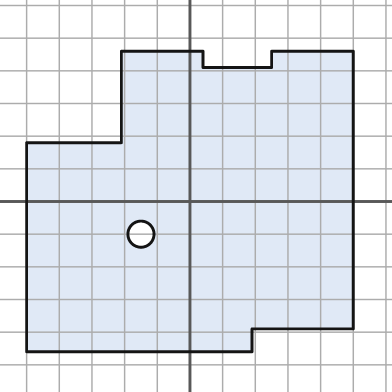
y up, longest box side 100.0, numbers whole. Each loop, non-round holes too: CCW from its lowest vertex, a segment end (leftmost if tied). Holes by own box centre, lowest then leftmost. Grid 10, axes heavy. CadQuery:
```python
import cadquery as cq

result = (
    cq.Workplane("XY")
    .moveTo(-50.0, -46.0)
    .lineTo(19.0, -46.0)
    .lineTo(19.0, -39.0)
    .lineTo(50.0, -39.0)
    .lineTo(50.0, 46.0)
    .lineTo(25.0, 46.0)
    .lineTo(25.0, 41.0)
    .lineTo(4.0, 41.0)
    .lineTo(4.0, 46.0)
    .lineTo(-21.0, 46.0)
    .lineTo(-21.0, 18.0)
    .lineTo(-50.0, 18.0)
    .close()
    .moveTo(-15.0, -10.0)
    .circle(4.0)
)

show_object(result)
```